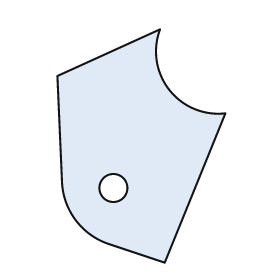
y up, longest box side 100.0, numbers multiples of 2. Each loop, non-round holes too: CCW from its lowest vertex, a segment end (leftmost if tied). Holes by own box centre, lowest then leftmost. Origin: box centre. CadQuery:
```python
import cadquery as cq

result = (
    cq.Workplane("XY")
    .moveTo(10.0, -50.0)
    .lineTo(36.0, 14.0)
    .threePointArc((12.0, 24.0), (8.0, 50.0))
    .lineTo(-36.0, 30.0)
    .lineTo(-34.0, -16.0)
    .threePointArc((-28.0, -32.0), (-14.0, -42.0))
    .close()
    .moveTo(-12.0, -18.0)
    .circle(6.0)
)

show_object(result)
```